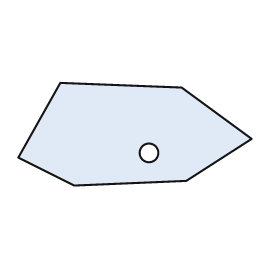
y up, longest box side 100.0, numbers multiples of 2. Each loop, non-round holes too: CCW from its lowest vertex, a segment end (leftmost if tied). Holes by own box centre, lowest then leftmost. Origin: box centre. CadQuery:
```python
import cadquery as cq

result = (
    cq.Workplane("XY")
    .moveTo(-26.0, -22.0)
    .lineTo(22.0, -20.0)
    .lineTo(50.0, -2.0)
    .lineTo(20.0, 20.0)
    .lineTo(-32.0, 22.0)
    .lineTo(-50.0, -10.0)
    .close()
    .moveTo(6.0, -8.0)
    .circle(4.0)
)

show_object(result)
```